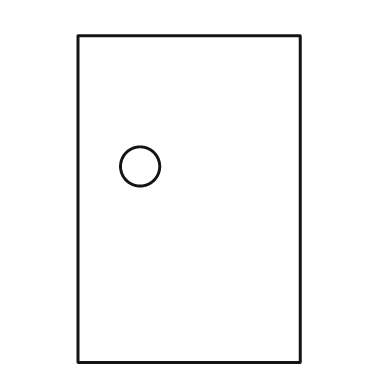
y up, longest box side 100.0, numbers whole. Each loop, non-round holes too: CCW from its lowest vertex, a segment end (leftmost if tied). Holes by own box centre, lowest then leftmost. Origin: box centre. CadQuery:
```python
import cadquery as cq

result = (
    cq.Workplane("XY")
    .moveTo(-34.0, -50.0)
    .lineTo(34.0, -50.0)
    .lineTo(34.0, 50.0)
    .lineTo(-34.0, 50.0)
    .close()
    .moveTo(-15.0, 10.0)
    .circle(6.0)
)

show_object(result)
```